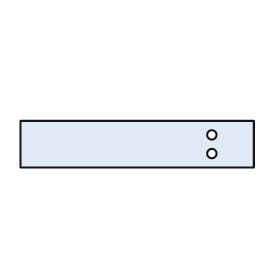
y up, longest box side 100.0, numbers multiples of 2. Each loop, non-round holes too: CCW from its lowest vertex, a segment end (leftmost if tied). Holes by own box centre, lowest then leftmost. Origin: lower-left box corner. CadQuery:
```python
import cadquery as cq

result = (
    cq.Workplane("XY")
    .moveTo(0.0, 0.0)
    .lineTo(100.0, 0.0)
    .lineTo(100.0, 20.0)
    .lineTo(0.0, 20.0)
    .close()
    .moveTo(82.0, 6.0)
    .circle(2.0)
    .moveTo(82.0, 14.0)
    .circle(2.0)
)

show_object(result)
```